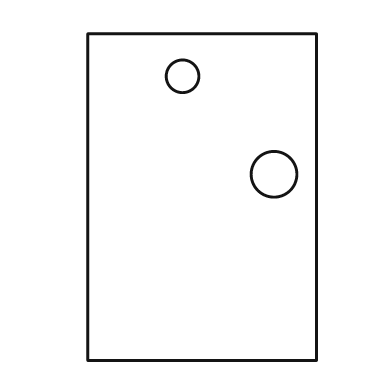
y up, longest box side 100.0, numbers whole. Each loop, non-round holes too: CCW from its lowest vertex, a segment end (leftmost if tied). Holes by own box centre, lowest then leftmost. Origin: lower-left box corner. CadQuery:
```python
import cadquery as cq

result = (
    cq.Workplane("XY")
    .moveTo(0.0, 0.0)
    .lineTo(70.0, 0.0)
    .lineTo(70.0, 100.0)
    .lineTo(0.0, 100.0)
    .close()
    .moveTo(57.0, 57.0)
    .circle(7.0)
    .moveTo(29.0, 87.0)
    .circle(5.0)
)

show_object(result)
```